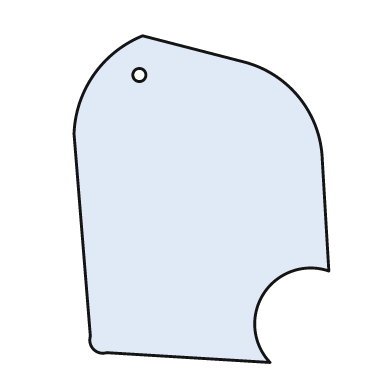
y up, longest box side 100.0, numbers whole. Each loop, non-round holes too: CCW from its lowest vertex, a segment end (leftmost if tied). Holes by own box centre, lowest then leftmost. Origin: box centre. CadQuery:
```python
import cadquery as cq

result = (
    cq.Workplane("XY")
    .moveTo(21.0, -50.0)
    .threePointArc((19.0, -29.0), (39.0, -22.0))
    .lineTo(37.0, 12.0)
    .threePointArc((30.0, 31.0), (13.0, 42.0))
    .lineTo(-18.0, 50.0)
    .threePointArc((-33.0, 38.0), (-39.0, 20.0))
    .lineTo(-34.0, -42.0)
    .threePointArc((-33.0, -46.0), (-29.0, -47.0))
    .close()
    .moveTo(-19.0, 38.0)
    .circle(2.0)
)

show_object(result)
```